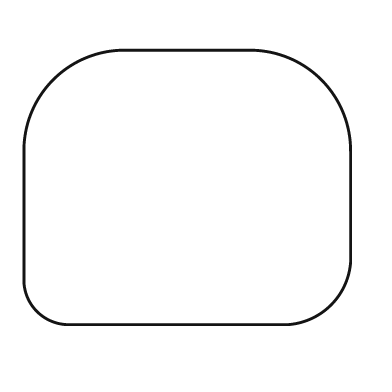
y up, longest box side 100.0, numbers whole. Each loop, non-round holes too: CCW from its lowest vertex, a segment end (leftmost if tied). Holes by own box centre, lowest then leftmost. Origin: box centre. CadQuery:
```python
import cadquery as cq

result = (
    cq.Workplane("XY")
    .moveTo(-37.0, -42.0)
    .lineTo(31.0, -42.0)
    .threePointArc((44.0, -36.0), (50.0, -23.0))
    .lineTo(50.0, 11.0)
    .threePointArc((41.0, 33.0), (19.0, 42.0))
    .lineTo(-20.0, 42.0)
    .threePointArc((-41.0, 33.0), (-50.0, 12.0))
    .lineTo(-50.0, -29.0)
    .threePointArc((-46.0, -38.0), (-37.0, -42.0))
    .close()
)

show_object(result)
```